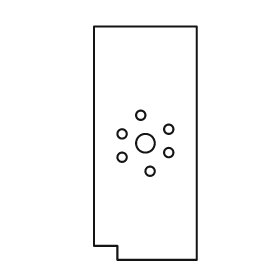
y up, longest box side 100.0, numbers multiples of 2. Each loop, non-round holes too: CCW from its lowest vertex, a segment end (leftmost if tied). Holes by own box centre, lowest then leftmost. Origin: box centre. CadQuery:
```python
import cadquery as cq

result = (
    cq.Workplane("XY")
    .moveTo(-12.0, -50.0)
    .lineTo(22.0, -50.0)
    .lineTo(22.0, 50.0)
    .lineTo(-22.0, 50.0)
    .lineTo(-22.0, -44.0)
    .lineTo(-12.0, -44.0)
    .close()
    .moveTo(2.0, -12.0)
    .circle(2.0)
    .moveTo(-10.0, -6.0)
    .circle(2.0)
    .moveTo(10.0, -4.0)
    .circle(2.0)
    .moveTo(0.0, 0.0)
    .circle(4.0)
    .moveTo(-10.0, 4.0)
    .circle(2.0)
    .moveTo(10.0, 6.0)
    .circle(2.0)
    .moveTo(-2.0, 12.0)
    .circle(2.0)
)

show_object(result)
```